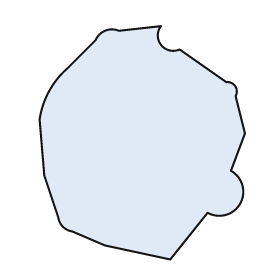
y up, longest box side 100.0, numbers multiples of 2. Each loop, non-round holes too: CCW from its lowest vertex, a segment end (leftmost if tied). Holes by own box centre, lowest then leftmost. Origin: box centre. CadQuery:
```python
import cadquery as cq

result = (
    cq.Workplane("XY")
    .moveTo(12.0, -50.0)
    .lineTo(28.0, -30.0)
    .threePointArc((42.0, -26.0), (38.0, -12.0))
    .lineTo(44.0, 4.0)
    .lineTo(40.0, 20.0)
    .threePointArc((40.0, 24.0), (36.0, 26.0))
    .lineTo(16.0, 40.0)
    .threePointArc((8.0, 42.0), (8.0, 50.0))
    .lineTo(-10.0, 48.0)
    .threePointArc((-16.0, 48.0), (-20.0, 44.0))
    .lineTo(-32.0, 32.0)
    .threePointArc((-40.0, 22.0), (-44.0, 10.0))
    .lineTo(-42.0, -14.0)
    .lineTo(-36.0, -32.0)
    .threePointArc((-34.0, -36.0), (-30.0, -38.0))
    .lineTo(-16.0, -44.0)
    .close()
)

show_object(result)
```